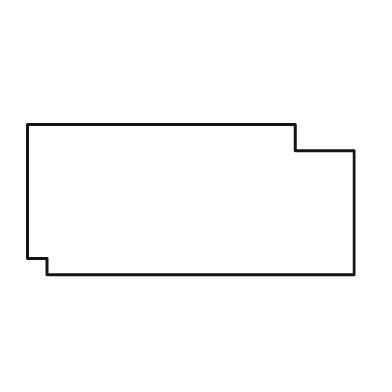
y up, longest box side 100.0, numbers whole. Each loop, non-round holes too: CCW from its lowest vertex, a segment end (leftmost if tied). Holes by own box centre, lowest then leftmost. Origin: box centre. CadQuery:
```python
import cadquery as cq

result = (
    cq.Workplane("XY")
    .moveTo(-44.0, -23.0)
    .lineTo(50.0, -23.0)
    .lineTo(50.0, 15.0)
    .lineTo(32.0, 15.0)
    .lineTo(32.0, 23.0)
    .lineTo(-50.0, 23.0)
    .lineTo(-50.0, -18.0)
    .lineTo(-44.0, -18.0)
    .close()
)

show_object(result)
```